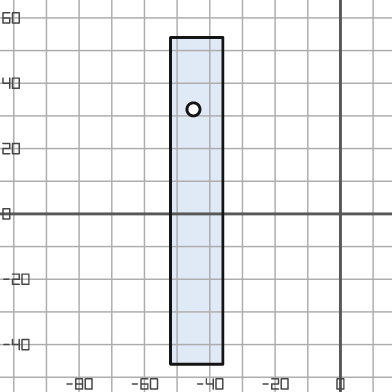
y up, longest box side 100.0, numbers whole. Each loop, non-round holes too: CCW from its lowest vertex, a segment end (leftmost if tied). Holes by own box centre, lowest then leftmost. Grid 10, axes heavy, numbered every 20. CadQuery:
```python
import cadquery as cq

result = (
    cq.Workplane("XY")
    .moveTo(-52.0, -46.0)
    .lineTo(-36.0, -46.0)
    .lineTo(-36.0, 54.0)
    .lineTo(-52.0, 54.0)
    .close()
    .moveTo(-45.0, 32.0)
    .circle(2.0)
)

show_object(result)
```